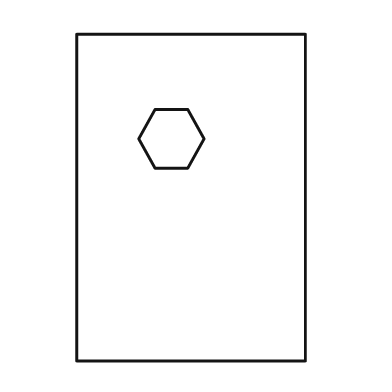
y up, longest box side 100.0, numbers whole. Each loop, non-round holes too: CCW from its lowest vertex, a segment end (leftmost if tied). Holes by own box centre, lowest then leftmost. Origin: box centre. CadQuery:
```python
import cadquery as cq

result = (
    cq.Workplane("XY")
    .moveTo(-35.0, -50.0)
    .lineTo(35.0, -50.0)
    .lineTo(35.0, 50.0)
    .lineTo(-35.0, 50.0)
    .close()
    .moveTo(-11.0, 9.0)
    .lineTo(-1.0, 9.0)
    .lineTo(4.0, 18.0)
    .lineTo(-1.0, 27.0)
    .lineTo(-11.0, 27.0)
    .lineTo(-16.0, 18.0)
    .close()
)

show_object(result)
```